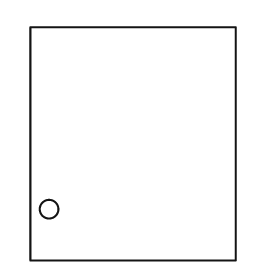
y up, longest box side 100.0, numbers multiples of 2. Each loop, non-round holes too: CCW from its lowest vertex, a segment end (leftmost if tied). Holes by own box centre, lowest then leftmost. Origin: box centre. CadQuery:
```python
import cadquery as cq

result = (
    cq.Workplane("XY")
    .moveTo(-44.0, -50.0)
    .lineTo(44.0, -50.0)
    .lineTo(44.0, 50.0)
    .lineTo(-44.0, 50.0)
    .close()
    .moveTo(-36.0, -28.0)
    .circle(4.0)
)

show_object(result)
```